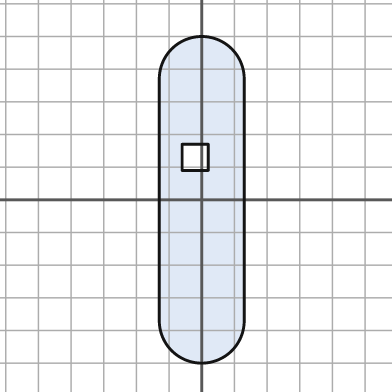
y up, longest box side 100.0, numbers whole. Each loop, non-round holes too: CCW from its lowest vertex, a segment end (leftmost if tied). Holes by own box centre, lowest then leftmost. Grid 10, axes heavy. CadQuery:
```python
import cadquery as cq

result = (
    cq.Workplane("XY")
    .moveTo(-13.0, -37.0)
    .threePointArc((0.0, -50.0), (13.0, -37.0))
    .lineTo(13.0, 37.0)
    .threePointArc((0.0, 50.0), (-13.0, 37.0))
    .close()
    .moveTo(-6.0, 9.0)
    .lineTo(2.0, 9.0)
    .lineTo(2.0, 17.0)
    .lineTo(-6.0, 17.0)
    .close()
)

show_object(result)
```